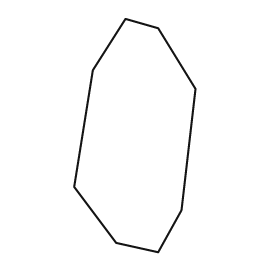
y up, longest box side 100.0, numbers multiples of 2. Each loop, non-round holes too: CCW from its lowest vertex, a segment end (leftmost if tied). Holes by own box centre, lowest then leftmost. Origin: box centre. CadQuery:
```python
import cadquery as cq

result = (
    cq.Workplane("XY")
    .moveTo(10.0, -50.0)
    .lineTo(20.0, -32.0)
    .lineTo(26.0, 20.0)
    .lineTo(10.0, 46.0)
    .lineTo(-4.0, 50.0)
    .lineTo(-18.0, 28.0)
    .lineTo(-26.0, -22.0)
    .lineTo(-8.0, -46.0)
    .close()
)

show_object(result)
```